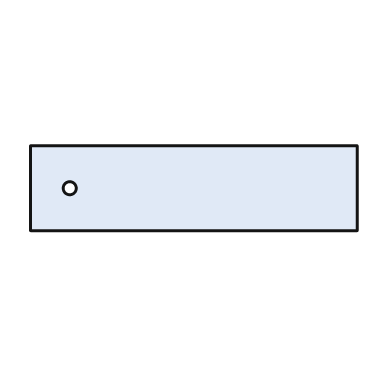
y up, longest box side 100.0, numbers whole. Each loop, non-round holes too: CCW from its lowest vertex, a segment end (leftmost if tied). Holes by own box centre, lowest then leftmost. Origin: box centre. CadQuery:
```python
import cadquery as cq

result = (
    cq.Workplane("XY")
    .moveTo(-50.0, -13.0)
    .lineTo(50.0, -13.0)
    .lineTo(50.0, 13.0)
    .lineTo(-50.0, 13.0)
    .close()
    .moveTo(-38.0, 0.0)
    .circle(2.0)
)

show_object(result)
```